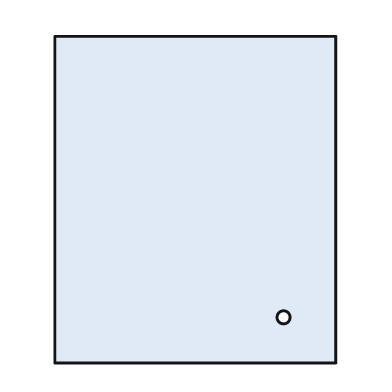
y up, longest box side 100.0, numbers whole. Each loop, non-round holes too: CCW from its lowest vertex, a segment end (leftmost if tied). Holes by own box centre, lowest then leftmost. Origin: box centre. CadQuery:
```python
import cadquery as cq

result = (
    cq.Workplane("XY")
    .moveTo(-43.0, -50.0)
    .lineTo(43.0, -50.0)
    .lineTo(43.0, 50.0)
    .lineTo(-43.0, 50.0)
    .close()
    .moveTo(27.0, -36.0)
    .circle(2.0)
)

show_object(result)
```